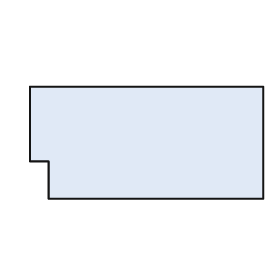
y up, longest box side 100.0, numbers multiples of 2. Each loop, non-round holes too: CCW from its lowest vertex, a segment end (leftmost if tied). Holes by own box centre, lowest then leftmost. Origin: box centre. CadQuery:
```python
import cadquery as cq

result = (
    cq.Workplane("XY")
    .moveTo(-42.0, -24.0)
    .lineTo(50.0, -24.0)
    .lineTo(50.0, 24.0)
    .lineTo(-50.0, 24.0)
    .lineTo(-50.0, -8.0)
    .lineTo(-42.0, -8.0)
    .close()
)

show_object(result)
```